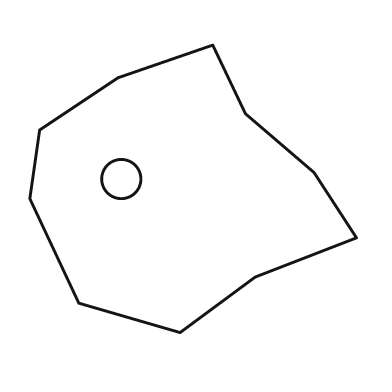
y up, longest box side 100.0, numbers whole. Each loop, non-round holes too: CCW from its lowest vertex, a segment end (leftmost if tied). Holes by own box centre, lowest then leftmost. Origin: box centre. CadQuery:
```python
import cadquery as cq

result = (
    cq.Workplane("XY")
    .moveTo(-4.0, -44.0)
    .lineTo(19.0, -27.0)
    .lineTo(50.0, -15.0)
    .lineTo(37.0, 5.0)
    .lineTo(16.0, 23.0)
    .lineTo(6.0, 44.0)
    .lineTo(-23.0, 34.0)
    .lineTo(-47.0, 18.0)
    .lineTo(-50.0, -3.0)
    .lineTo(-35.0, -35.0)
    .close()
    .moveTo(-22.0, 3.0)
    .circle(6.0)
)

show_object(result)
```